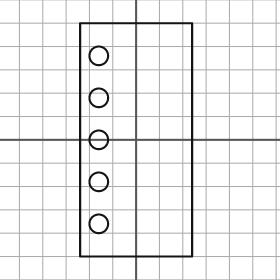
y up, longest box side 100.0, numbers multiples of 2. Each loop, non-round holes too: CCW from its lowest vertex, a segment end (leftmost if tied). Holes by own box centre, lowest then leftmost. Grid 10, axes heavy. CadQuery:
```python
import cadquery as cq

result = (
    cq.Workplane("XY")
    .moveTo(-24.0, -50.0)
    .lineTo(24.0, -50.0)
    .lineTo(24.0, 50.0)
    .lineTo(-24.0, 50.0)
    .close()
    .moveTo(-16.0, -36.0)
    .circle(4.0)
    .moveTo(-16.0, -18.0)
    .circle(4.0)
    .moveTo(-16.0, 0.0)
    .circle(4.0)
    .moveTo(-16.0, 18.0)
    .circle(4.0)
    .moveTo(-16.0, 36.0)
    .circle(4.0)
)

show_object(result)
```